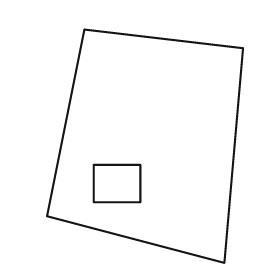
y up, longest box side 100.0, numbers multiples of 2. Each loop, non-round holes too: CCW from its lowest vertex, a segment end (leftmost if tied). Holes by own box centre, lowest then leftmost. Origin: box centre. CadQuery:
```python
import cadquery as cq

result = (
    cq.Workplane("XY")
    .moveTo(34.0, -50.0)
    .lineTo(42.0, 42.0)
    .lineTo(-26.0, 50.0)
    .lineTo(-42.0, -30.0)
    .close()
    .moveTo(-22.0, -24.0)
    .lineTo(-2.0, -24.0)
    .lineTo(-2.0, -8.0)
    .lineTo(-22.0, -8.0)
    .close()
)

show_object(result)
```